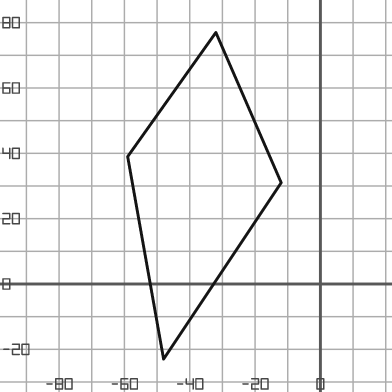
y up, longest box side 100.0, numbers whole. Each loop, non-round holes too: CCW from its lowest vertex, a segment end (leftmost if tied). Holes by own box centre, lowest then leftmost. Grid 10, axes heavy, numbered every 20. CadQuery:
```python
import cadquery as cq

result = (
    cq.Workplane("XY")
    .moveTo(-48.0, -23.0)
    .lineTo(-12.0, 31.0)
    .lineTo(-32.0, 77.0)
    .lineTo(-59.0, 39.0)
    .close()
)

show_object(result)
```